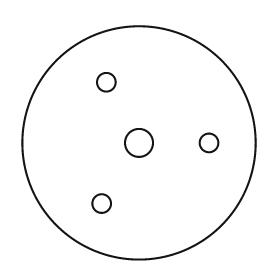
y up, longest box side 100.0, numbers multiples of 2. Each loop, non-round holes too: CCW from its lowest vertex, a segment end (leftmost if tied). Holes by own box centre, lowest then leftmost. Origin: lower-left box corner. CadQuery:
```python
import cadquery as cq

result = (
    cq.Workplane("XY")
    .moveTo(50.0, 50.0)
    .circle(50.0)
    .moveTo(34.0, 24.0)
    .circle(4.0)
    .moveTo(50.0, 50.0)
    .circle(6.0)
    .moveTo(80.0, 50.0)
    .circle(4.0)
    .moveTo(36.0, 76.0)
    .circle(4.0)
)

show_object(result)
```